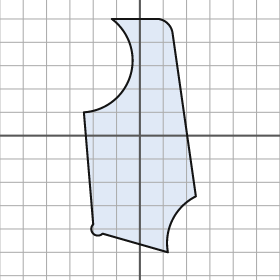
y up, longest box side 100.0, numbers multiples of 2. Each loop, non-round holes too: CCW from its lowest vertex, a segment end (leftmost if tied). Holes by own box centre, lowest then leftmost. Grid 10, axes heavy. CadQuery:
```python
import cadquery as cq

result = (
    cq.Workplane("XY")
    .moveTo(12.0, -50.0)
    .threePointArc((14.0, -36.0), (24.0, -26.0))
    .lineTo(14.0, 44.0)
    .threePointArc((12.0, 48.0), (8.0, 50.0))
    .lineTo(-12.0, 50.0)
    .threePointArc((-4.0, 26.0), (-24.0, 10.0))
    .lineTo(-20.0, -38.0)
    .threePointArc((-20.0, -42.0), (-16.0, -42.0))
    .close()
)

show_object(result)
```